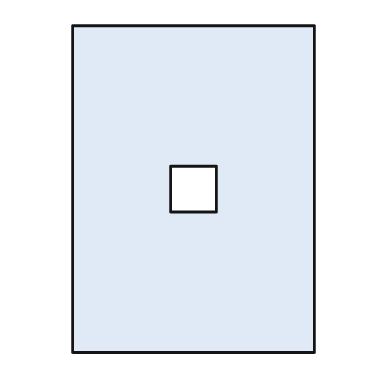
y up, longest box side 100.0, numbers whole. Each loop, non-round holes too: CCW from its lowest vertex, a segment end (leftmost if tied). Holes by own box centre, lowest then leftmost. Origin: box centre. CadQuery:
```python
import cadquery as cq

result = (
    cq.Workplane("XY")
    .moveTo(-37.0, -50.0)
    .lineTo(37.0, -50.0)
    .lineTo(37.0, 50.0)
    .lineTo(-37.0, 50.0)
    .close()
    .moveTo(-7.0, -7.0)
    .lineTo(7.0, -7.0)
    .lineTo(7.0, 7.0)
    .lineTo(-7.0, 7.0)
    .close()
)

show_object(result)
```